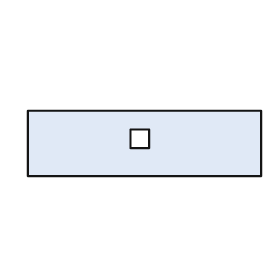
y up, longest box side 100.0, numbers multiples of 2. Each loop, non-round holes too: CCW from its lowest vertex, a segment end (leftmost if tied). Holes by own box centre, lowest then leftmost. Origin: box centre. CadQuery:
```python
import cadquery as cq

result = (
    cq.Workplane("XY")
    .moveTo(-50.0, -14.0)
    .lineTo(50.0, -14.0)
    .lineTo(50.0, 14.0)
    .lineTo(-50.0, 14.0)
    .close()
    .moveTo(-6.0, -2.0)
    .lineTo(2.0, -2.0)
    .lineTo(2.0, 6.0)
    .lineTo(-6.0, 6.0)
    .close()
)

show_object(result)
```